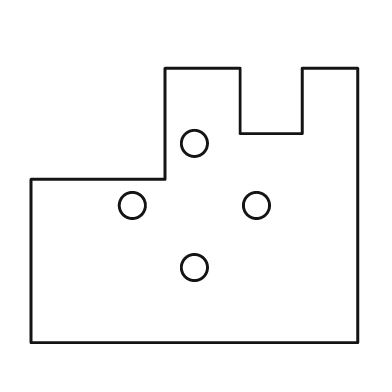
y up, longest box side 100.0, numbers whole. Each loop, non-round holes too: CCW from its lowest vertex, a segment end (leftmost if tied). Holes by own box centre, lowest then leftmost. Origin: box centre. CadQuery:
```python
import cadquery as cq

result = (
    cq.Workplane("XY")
    .moveTo(-50.0, -42.0)
    .lineTo(50.0, -42.0)
    .lineTo(50.0, 42.0)
    .lineTo(33.0, 42.0)
    .lineTo(33.0, 22.0)
    .lineTo(14.0, 22.0)
    .lineTo(14.0, 42.0)
    .lineTo(-9.0, 42.0)
    .lineTo(-9.0, 8.0)
    .lineTo(-50.0, 8.0)
    .close()
    .moveTo(0.0, -19.0)
    .circle(4.0)
    .moveTo(-19.0, 0.0)
    .circle(4.0)
    .moveTo(19.0, 0.0)
    .circle(4.0)
    .moveTo(0.0, 19.0)
    .circle(4.0)
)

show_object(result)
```